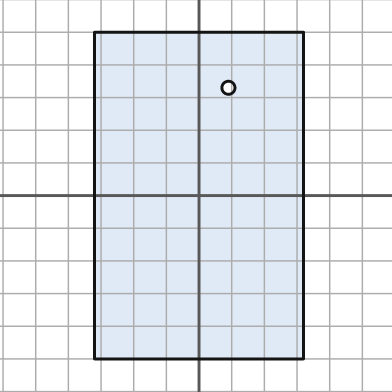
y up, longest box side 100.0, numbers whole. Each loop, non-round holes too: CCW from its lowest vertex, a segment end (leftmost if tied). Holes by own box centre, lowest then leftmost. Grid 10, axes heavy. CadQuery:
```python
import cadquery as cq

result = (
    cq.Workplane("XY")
    .moveTo(-32.0, -50.0)
    .lineTo(32.0, -50.0)
    .lineTo(32.0, 50.0)
    .lineTo(-32.0, 50.0)
    .close()
    .moveTo(9.0, 33.0)
    .circle(2.0)
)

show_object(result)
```